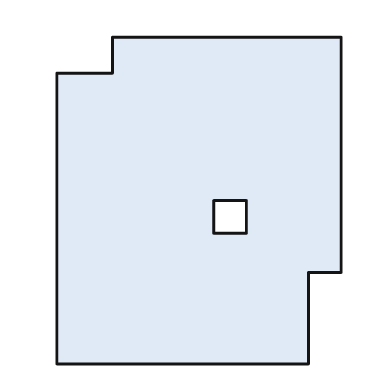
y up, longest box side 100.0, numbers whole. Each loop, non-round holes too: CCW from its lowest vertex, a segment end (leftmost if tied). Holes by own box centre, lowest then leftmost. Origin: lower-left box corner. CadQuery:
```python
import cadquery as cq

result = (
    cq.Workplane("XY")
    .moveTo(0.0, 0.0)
    .lineTo(77.0, 0.0)
    .lineTo(77.0, 28.0)
    .lineTo(87.0, 28.0)
    .lineTo(87.0, 100.0)
    .lineTo(17.0, 100.0)
    .lineTo(17.0, 89.0)
    .lineTo(0.0, 89.0)
    .close()
    .moveTo(48.0, 40.0)
    .lineTo(58.0, 40.0)
    .lineTo(58.0, 50.0)
    .lineTo(48.0, 50.0)
    .close()
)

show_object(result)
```